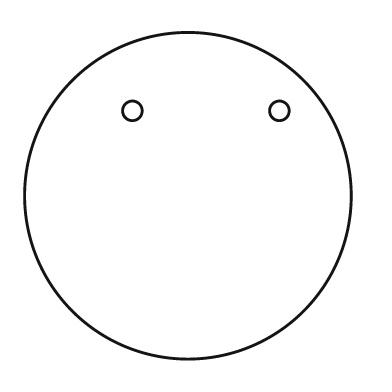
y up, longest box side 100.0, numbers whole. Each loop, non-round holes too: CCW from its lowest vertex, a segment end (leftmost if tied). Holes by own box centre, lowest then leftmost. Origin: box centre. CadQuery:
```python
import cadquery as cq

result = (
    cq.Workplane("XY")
    .moveTo(0.0, 0.0)
    .circle(50.0)
    .moveTo(-17.0, 26.0)
    .circle(3.0)
    .moveTo(28.0, 26.0)
    .circle(3.0)
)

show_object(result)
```